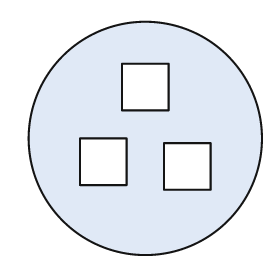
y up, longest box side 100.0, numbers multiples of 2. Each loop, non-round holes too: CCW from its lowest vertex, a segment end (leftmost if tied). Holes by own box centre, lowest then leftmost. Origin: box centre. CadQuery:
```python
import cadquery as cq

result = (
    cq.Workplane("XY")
    .moveTo(0.0, 0.0)
    .circle(50.0)
    .moveTo(8.0, -22.0)
    .lineTo(28.0, -22.0)
    .lineTo(28.0, -2.0)
    .lineTo(8.0, -2.0)
    .close()
    .moveTo(-28.0, -20.0)
    .lineTo(-8.0, -20.0)
    .lineTo(-8.0, 0.0)
    .lineTo(-28.0, 0.0)
    .close()
    .moveTo(-10.0, 12.0)
    .lineTo(10.0, 12.0)
    .lineTo(10.0, 32.0)
    .lineTo(-10.0, 32.0)
    .close()
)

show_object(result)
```